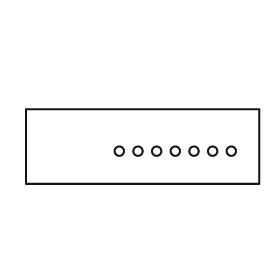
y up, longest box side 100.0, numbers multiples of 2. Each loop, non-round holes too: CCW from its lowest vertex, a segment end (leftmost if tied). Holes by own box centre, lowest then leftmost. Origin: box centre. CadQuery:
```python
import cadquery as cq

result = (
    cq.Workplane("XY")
    .moveTo(-50.0, -16.0)
    .lineTo(50.0, -16.0)
    .lineTo(50.0, 16.0)
    .lineTo(-50.0, 16.0)
    .close()
    .moveTo(-10.0, -2.0)
    .circle(2.0)
    .moveTo(-2.0, -2.0)
    .circle(2.0)
    .moveTo(6.0, -2.0)
    .circle(2.0)
    .moveTo(14.0, -2.0)
    .circle(2.0)
    .moveTo(22.0, -2.0)
    .circle(2.0)
    .moveTo(30.0, -2.0)
    .circle(2.0)
    .moveTo(38.0, -2.0)
    .circle(2.0)
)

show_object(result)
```